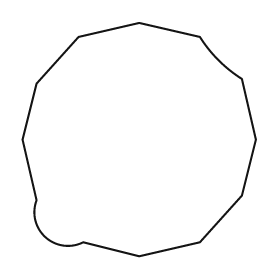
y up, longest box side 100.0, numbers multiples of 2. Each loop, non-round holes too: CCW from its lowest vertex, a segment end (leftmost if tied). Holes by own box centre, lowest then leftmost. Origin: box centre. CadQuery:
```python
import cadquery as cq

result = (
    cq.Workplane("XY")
    .moveTo(0.0, -50.0)
    .lineTo(26.0, -44.0)
    .lineTo(44.0, -24.0)
    .lineTo(50.0, 0.0)
    .lineTo(44.0, 26.0)
    .threePointArc((34.0, 34.0), (26.0, 44.0))
    .lineTo(0.0, 50.0)
    .lineTo(-26.0, 44.0)
    .lineTo(-44.0, 24.0)
    .lineTo(-50.0, 0.0)
    .lineTo(-44.0, -26.0)
    .threePointArc((-40.0, -42.0), (-24.0, -44.0))
    .close()
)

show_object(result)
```